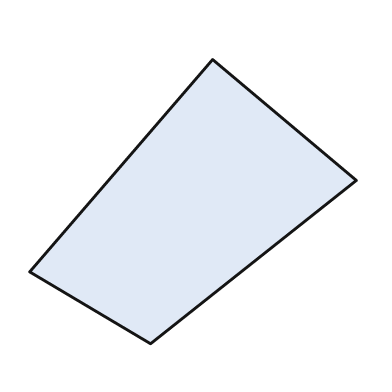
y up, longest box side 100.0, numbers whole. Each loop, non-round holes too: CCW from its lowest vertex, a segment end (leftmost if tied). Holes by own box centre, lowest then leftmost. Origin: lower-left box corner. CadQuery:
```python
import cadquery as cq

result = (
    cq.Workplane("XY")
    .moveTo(37.0, 0.0)
    .lineTo(100.0, 50.0)
    .lineTo(56.0, 87.0)
    .lineTo(0.0, 22.0)
    .close()
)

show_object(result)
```